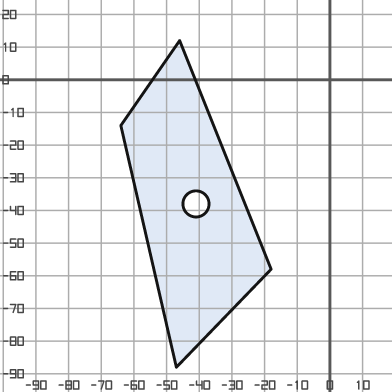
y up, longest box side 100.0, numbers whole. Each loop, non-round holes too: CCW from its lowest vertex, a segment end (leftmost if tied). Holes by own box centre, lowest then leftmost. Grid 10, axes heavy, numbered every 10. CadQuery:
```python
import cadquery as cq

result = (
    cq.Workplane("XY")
    .moveTo(-47.0, -88.0)
    .lineTo(-18.0, -58.0)
    .lineTo(-46.0, 12.0)
    .lineTo(-64.0, -14.0)
    .close()
    .moveTo(-41.0, -38.0)
    .circle(4.0)
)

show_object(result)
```